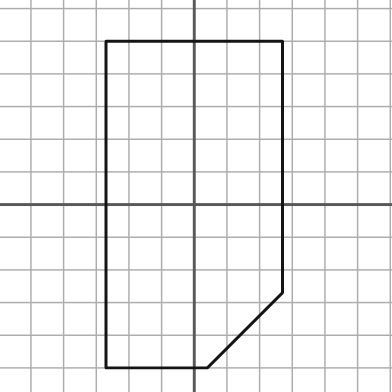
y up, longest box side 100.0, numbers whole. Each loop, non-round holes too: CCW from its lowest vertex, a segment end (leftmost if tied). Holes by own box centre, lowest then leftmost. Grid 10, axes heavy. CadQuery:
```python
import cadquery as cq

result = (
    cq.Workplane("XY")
    .moveTo(-27.0, -50.0)
    .lineTo(4.0, -50.0)
    .lineTo(27.0, -27.0)
    .lineTo(27.0, 50.0)
    .lineTo(-27.0, 50.0)
    .close()
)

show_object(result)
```